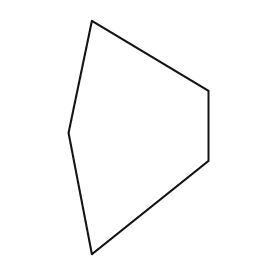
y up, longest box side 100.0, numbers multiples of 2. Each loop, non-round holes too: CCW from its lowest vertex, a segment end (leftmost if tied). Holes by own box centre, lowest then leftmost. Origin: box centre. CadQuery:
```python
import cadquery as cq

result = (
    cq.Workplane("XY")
    .moveTo(-20.0, -50.0)
    .lineTo(30.0, -10.0)
    .lineTo(30.0, 20.0)
    .lineTo(-20.0, 50.0)
    .lineTo(-30.0, 2.0)
    .close()
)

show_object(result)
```